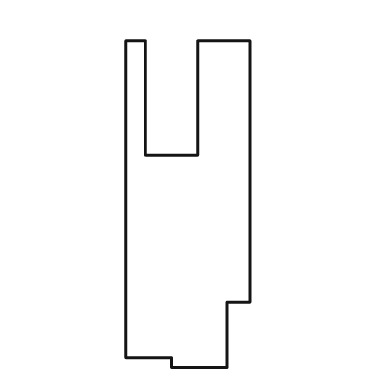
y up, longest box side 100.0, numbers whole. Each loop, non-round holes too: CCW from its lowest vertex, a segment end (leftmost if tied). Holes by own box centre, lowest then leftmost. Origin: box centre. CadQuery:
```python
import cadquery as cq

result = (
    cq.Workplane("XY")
    .moveTo(-5.0, -50.0)
    .lineTo(12.0, -50.0)
    .lineTo(12.0, -30.0)
    .lineTo(19.0, -30.0)
    .lineTo(19.0, 50.0)
    .lineTo(3.0, 50.0)
    .lineTo(3.0, 15.0)
    .lineTo(-13.0, 15.0)
    .lineTo(-13.0, 50.0)
    .lineTo(-19.0, 50.0)
    .lineTo(-19.0, -47.0)
    .lineTo(-5.0, -47.0)
    .close()
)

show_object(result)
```